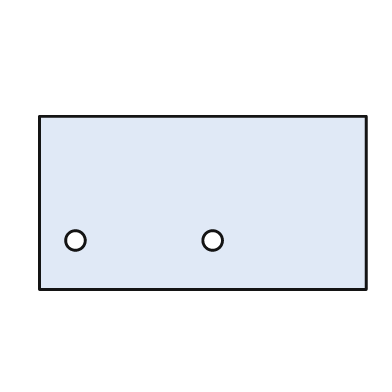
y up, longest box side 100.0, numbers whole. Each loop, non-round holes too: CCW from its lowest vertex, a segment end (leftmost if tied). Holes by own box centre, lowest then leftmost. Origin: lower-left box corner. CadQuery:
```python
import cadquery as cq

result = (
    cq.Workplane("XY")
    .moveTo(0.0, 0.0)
    .lineTo(100.0, 0.0)
    .lineTo(100.0, 53.0)
    .lineTo(0.0, 53.0)
    .close()
    .moveTo(11.0, 15.0)
    .circle(3.0)
    .moveTo(53.0, 15.0)
    .circle(3.0)
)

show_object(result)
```